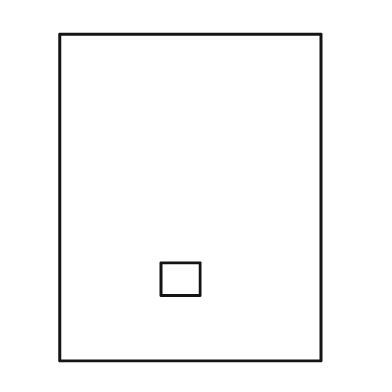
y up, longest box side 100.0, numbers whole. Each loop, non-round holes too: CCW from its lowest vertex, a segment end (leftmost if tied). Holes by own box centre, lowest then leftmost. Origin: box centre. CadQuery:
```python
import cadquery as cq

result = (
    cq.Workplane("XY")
    .moveTo(-40.0, -50.0)
    .lineTo(40.0, -50.0)
    .lineTo(40.0, 50.0)
    .lineTo(-40.0, 50.0)
    .close()
    .moveTo(-9.0, -30.0)
    .lineTo(3.0, -30.0)
    .lineTo(3.0, -20.0)
    .lineTo(-9.0, -20.0)
    .close()
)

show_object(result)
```